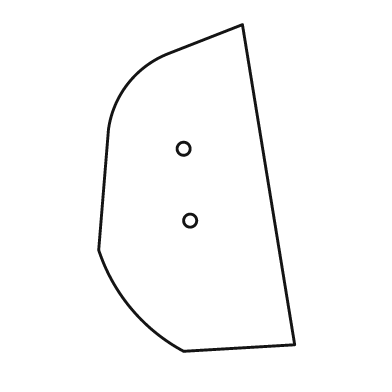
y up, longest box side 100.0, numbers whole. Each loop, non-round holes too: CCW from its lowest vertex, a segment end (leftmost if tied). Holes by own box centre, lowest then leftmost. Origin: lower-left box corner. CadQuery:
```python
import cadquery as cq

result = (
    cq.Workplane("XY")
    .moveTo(26.0, 0.0)
    .lineTo(60.0, 2.0)
    .lineTo(44.0, 100.0)
    .lineTo(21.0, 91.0)
    .threePointArc((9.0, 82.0), (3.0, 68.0))
    .lineTo(0.0, 31.0)
    .threePointArc((10.0, 13.0), (26.0, 0.0))
    .close()
    .moveTo(28.0, 40.0)
    .circle(2.0)
    .moveTo(26.0, 62.0)
    .circle(2.0)
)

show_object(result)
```